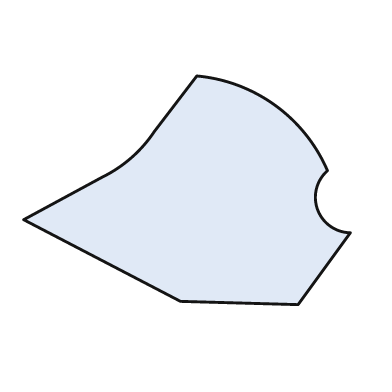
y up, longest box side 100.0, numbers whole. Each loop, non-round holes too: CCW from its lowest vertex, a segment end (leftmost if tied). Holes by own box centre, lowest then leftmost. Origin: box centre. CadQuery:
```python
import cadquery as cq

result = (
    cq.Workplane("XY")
    .moveTo(34.0, -35.0)
    .lineTo(50.0, -13.0)
    .threePointArc((40.0, -6.0), (43.0, 6.0))
    .threePointArc((27.0, 26.0), (3.0, 35.0))
    .lineTo(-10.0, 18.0)
    .threePointArc((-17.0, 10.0), (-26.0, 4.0))
    .lineTo(-50.0, -9.0)
    .lineTo(-2.0, -34.0)
    .close()
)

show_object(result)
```